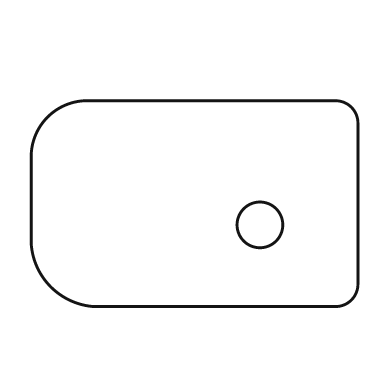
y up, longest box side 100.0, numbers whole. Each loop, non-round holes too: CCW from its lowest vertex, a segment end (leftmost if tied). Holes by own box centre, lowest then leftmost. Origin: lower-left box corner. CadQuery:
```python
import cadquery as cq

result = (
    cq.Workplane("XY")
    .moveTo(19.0, 0.0)
    .lineTo(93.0, 0.0)
    .threePointArc((98.0, 2.0), (100.0, 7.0))
    .lineTo(100.0, 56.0)
    .threePointArc((98.0, 61.0), (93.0, 63.0))
    .lineTo(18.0, 63.0)
    .threePointArc((5.0, 58.0), (0.0, 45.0))
    .lineTo(0.0, 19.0)
    .threePointArc((6.0, 6.0), (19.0, 0.0))
    .close()
    .moveTo(70.0, 25.0)
    .circle(7.0)
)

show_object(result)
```